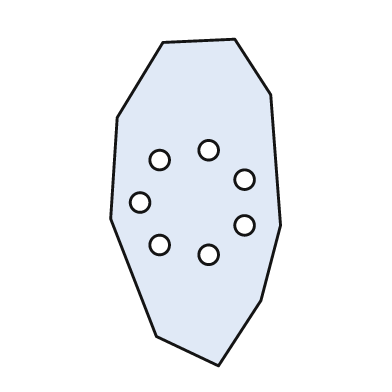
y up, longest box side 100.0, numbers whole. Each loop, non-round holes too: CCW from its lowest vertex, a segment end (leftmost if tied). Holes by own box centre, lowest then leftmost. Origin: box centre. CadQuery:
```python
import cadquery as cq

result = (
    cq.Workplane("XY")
    .moveTo(7.0, -50.0)
    .lineTo(20.0, -30.0)
    .lineTo(26.0, -7.0)
    .lineTo(23.0, 33.0)
    .lineTo(12.0, 50.0)
    .lineTo(-10.0, 49.0)
    .lineTo(-24.0, 26.0)
    .lineTo(-26.0, -5.0)
    .lineTo(-12.0, -41.0)
    .close()
    .moveTo(4.0, -16.0)
    .circle(3.0)
    .moveTo(-11.0, -13.0)
    .circle(3.0)
    .moveTo(15.0, -7.0)
    .circle(3.0)
    .moveTo(-17.0, 0.0)
    .circle(3.0)
    .moveTo(15.0, 7.0)
    .circle(3.0)
    .moveTo(-11.0, 13.0)
    .circle(3.0)
    .moveTo(4.0, 16.0)
    .circle(3.0)
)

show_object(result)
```